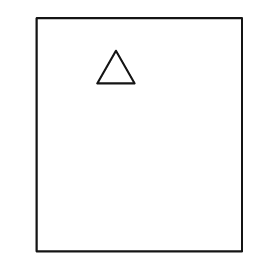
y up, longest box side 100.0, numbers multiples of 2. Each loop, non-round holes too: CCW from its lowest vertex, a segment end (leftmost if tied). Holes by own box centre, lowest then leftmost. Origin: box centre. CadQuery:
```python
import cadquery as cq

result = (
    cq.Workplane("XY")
    .moveTo(-44.0, -50.0)
    .lineTo(44.0, -50.0)
    .lineTo(44.0, 50.0)
    .lineTo(-44.0, 50.0)
    .close()
    .moveTo(-18.0, 22.0)
    .lineTo(-2.0, 22.0)
    .lineTo(-10.0, 36.0)
    .close()
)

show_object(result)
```